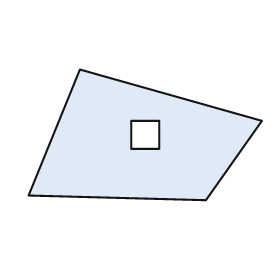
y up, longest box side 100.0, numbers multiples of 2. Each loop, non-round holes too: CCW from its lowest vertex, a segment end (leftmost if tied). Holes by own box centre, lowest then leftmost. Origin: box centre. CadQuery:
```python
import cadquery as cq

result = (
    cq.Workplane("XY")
    .moveTo(26.0, -28.0)
    .lineTo(50.0, 6.0)
    .lineTo(-28.0, 28.0)
    .lineTo(-50.0, -26.0)
    .close()
    .moveTo(-6.0, -6.0)
    .lineTo(6.0, -6.0)
    .lineTo(6.0, 6.0)
    .lineTo(-6.0, 6.0)
    .close()
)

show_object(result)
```